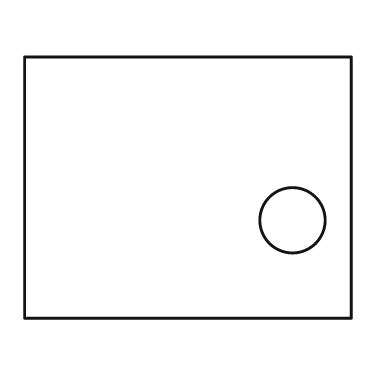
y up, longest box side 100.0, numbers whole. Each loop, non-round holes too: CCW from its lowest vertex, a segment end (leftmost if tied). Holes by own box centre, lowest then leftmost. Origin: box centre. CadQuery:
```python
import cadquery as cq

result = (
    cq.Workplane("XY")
    .moveTo(-50.0, -40.0)
    .lineTo(50.0, -40.0)
    .lineTo(50.0, 40.0)
    .lineTo(-50.0, 40.0)
    .close()
    .moveTo(32.0, -10.0)
    .circle(10.0)
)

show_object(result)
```